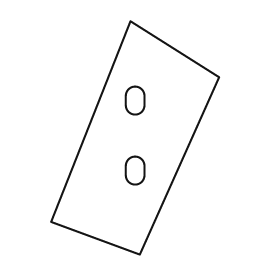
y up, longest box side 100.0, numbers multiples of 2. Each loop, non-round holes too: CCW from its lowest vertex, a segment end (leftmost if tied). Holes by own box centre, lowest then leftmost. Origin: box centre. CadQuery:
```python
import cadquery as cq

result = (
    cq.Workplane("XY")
    .moveTo(2.0, -50.0)
    .lineTo(36.0, 26.0)
    .lineTo(-2.0, 50.0)
    .lineTo(-36.0, -36.0)
    .close()
    .moveTo(-4.0, -16.0)
    .threePointArc((0.0, -20.0), (4.0, -16.0))
    .lineTo(4.0, -12.0)
    .threePointArc((0.0, -8.0), (-4.0, -12.0))
    .close()
    .moveTo(-4.0, 14.0)
    .threePointArc((0.0, 10.0), (4.0, 14.0))
    .lineTo(4.0, 18.0)
    .threePointArc((0.0, 22.0), (-4.0, 18.0))
    .close()
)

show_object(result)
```